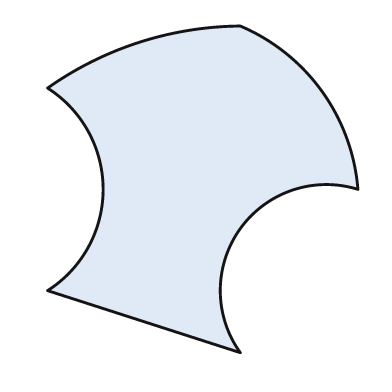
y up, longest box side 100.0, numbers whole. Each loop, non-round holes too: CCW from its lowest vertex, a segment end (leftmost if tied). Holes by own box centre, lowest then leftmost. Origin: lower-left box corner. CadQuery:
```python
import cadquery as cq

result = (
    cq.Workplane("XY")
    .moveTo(59.0, 0.0)
    .threePointArc((59.0, 38.0), (95.0, 50.0))
    .threePointArc((84.0, 80.0), (59.0, 100.0))
    .threePointArc((28.0, 95.0), (0.0, 81.0))
    .threePointArc((17.0, 50.0), (0.0, 19.0))
    .close()
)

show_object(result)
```